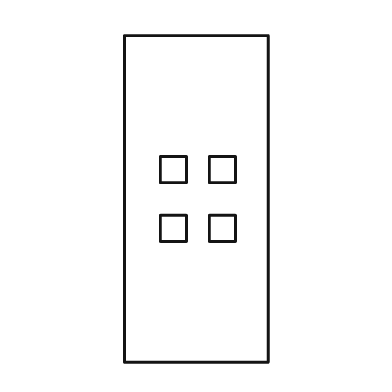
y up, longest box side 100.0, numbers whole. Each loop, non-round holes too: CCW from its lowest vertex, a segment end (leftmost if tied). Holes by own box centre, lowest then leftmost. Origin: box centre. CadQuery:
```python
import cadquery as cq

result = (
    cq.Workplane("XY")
    .moveTo(-22.0, -50.0)
    .lineTo(22.0, -50.0)
    .lineTo(22.0, 50.0)
    .lineTo(-22.0, 50.0)
    .close()
    .moveTo(-11.0, -13.0)
    .lineTo(-3.0, -13.0)
    .lineTo(-3.0, -5.0)
    .lineTo(-11.0, -5.0)
    .close()
    .moveTo(4.0, -13.0)
    .lineTo(12.0, -13.0)
    .lineTo(12.0, -5.0)
    .lineTo(4.0, -5.0)
    .close()
    .moveTo(-11.0, 5.0)
    .lineTo(-3.0, 5.0)
    .lineTo(-3.0, 13.0)
    .lineTo(-11.0, 13.0)
    .close()
    .moveTo(4.0, 5.0)
    .lineTo(12.0, 5.0)
    .lineTo(12.0, 13.0)
    .lineTo(4.0, 13.0)
    .close()
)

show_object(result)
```